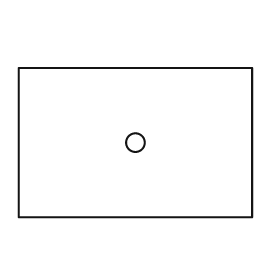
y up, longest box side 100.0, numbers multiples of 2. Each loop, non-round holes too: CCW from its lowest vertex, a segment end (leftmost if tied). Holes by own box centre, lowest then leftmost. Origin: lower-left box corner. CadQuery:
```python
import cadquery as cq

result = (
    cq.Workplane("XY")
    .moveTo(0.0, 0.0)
    .lineTo(100.0, 0.0)
    .lineTo(100.0, 64.0)
    .lineTo(0.0, 64.0)
    .close()
    .moveTo(50.0, 32.0)
    .circle(4.0)
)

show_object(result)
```